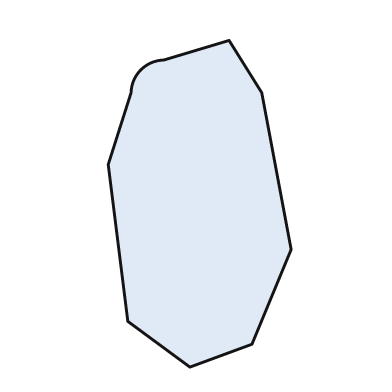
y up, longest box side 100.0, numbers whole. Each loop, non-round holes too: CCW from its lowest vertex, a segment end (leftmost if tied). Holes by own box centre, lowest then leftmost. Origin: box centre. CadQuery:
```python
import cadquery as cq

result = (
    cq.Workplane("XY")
    .moveTo(-3.0, -50.0)
    .lineTo(16.0, -43.0)
    .lineTo(28.0, -14.0)
    .lineTo(19.0, 34.0)
    .lineTo(9.0, 50.0)
    .lineTo(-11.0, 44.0)
    .threePointArc((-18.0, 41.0), (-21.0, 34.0))
    .lineTo(-28.0, 12.0)
    .lineTo(-22.0, -36.0)
    .close()
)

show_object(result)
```